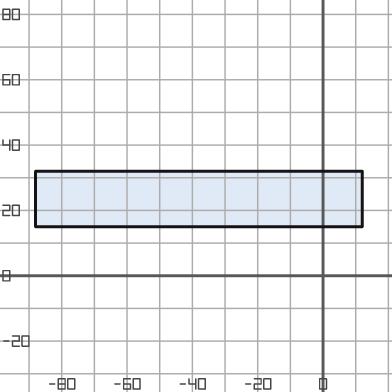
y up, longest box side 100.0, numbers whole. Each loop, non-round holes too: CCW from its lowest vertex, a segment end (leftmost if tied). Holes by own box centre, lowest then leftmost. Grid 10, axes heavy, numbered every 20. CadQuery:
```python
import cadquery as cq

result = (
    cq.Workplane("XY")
    .moveTo(-88.0, 15.0)
    .lineTo(12.0, 15.0)
    .lineTo(12.0, 32.0)
    .lineTo(-88.0, 32.0)
    .close()
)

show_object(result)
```